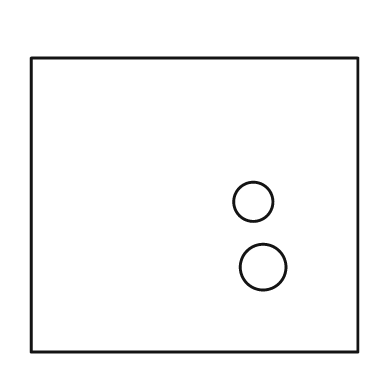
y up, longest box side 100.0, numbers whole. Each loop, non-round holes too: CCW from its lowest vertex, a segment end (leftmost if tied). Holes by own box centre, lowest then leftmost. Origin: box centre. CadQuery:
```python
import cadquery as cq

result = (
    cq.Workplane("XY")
    .moveTo(-50.0, -45.0)
    .lineTo(50.0, -45.0)
    .lineTo(50.0, 45.0)
    .lineTo(-50.0, 45.0)
    .close()
    .moveTo(21.0, -19.0)
    .circle(7.0)
    .moveTo(18.0, 1.0)
    .circle(6.0)
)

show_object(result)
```